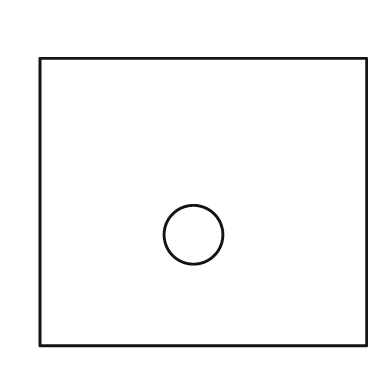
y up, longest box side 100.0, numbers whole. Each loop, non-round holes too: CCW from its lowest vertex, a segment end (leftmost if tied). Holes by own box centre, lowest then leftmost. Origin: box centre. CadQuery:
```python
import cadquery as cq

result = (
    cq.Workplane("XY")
    .moveTo(-50.0, -44.0)
    .lineTo(50.0, -44.0)
    .lineTo(50.0, 44.0)
    .lineTo(-50.0, 44.0)
    .close()
    .moveTo(-3.0, -10.0)
    .circle(9.0)
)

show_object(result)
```